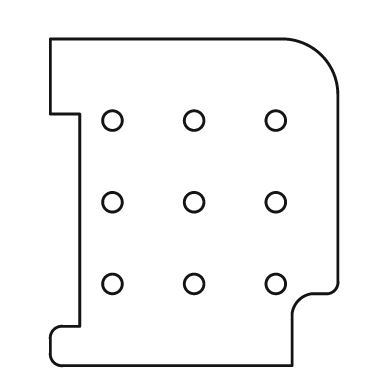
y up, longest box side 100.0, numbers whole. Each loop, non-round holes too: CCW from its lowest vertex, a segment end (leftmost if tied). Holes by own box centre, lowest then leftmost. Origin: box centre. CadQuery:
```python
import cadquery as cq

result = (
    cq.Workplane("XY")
    .moveTo(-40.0, -50.0)
    .lineTo(30.0, -50.0)
    .lineTo(30.0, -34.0)
    .threePointArc((32.0, -30.0), (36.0, -28.0))
    .lineTo(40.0, -28.0)
    .threePointArc((43.0, -27.0), (44.0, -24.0))
    .lineTo(44.0, 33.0)
    .threePointArc((39.0, 45.0), (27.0, 50.0))
    .lineTo(-44.0, 50.0)
    .lineTo(-44.0, 27.0)
    .lineTo(-35.0, 27.0)
    .lineTo(-35.0, -38.0)
    .lineTo(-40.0, -38.0)
    .threePointArc((-43.0, -39.0), (-44.0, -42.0))
    .lineTo(-44.0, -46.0)
    .threePointArc((-43.0, -49.0), (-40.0, -50.0))
    .close()
    .moveTo(-25.0, -25.0)
    .circle(3.0)
    .moveTo(0.0, -25.0)
    .circle(3.0)
    .moveTo(25.0, -25.0)
    .circle(3.0)
    .moveTo(-25.0, 0.0)
    .circle(3.0)
    .moveTo(0.0, 0.0)
    .circle(3.0)
    .moveTo(25.0, 0.0)
    .circle(3.0)
    .moveTo(-25.0, 25.0)
    .circle(3.0)
    .moveTo(0.0, 25.0)
    .circle(3.0)
    .moveTo(25.0, 25.0)
    .circle(3.0)
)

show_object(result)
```